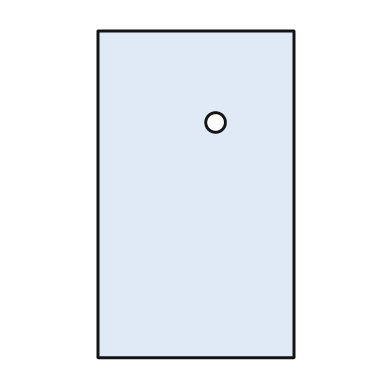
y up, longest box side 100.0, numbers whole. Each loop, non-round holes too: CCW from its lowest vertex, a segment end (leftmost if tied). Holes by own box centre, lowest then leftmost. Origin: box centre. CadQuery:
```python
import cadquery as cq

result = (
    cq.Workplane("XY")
    .moveTo(-30.0, -50.0)
    .lineTo(30.0, -50.0)
    .lineTo(30.0, 50.0)
    .lineTo(-30.0, 50.0)
    .close()
    .moveTo(6.0, 22.0)
    .circle(3.0)
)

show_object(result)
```